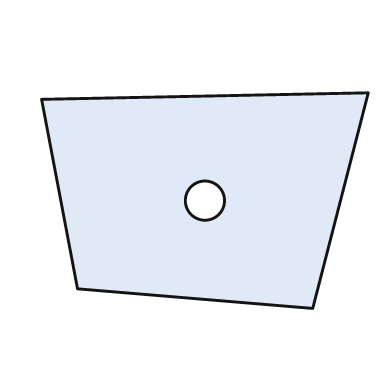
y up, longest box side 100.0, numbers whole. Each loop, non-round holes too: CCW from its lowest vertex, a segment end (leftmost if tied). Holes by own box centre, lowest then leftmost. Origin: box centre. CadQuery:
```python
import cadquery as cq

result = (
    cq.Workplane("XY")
    .moveTo(33.0, -33.0)
    .lineTo(50.0, 33.0)
    .lineTo(-50.0, 31.0)
    .lineTo(-39.0, -27.0)
    .close()
    .moveTo(0.0, 0.0)
    .circle(6.0)
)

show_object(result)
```